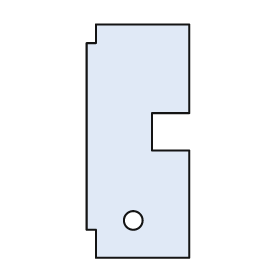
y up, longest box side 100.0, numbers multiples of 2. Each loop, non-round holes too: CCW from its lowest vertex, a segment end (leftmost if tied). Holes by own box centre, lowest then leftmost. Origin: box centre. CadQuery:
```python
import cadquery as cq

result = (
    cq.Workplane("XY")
    .moveTo(-18.0, -50.0)
    .lineTo(22.0, -50.0)
    .lineTo(22.0, -4.0)
    .lineTo(6.0, -4.0)
    .lineTo(6.0, 12.0)
    .lineTo(22.0, 12.0)
    .lineTo(22.0, 50.0)
    .lineTo(-18.0, 50.0)
    .lineTo(-18.0, 42.0)
    .lineTo(-22.0, 42.0)
    .lineTo(-22.0, -38.0)
    .lineTo(-18.0, -38.0)
    .close()
    .moveTo(-2.0, -34.0)
    .circle(4.0)
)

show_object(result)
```